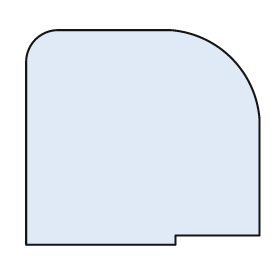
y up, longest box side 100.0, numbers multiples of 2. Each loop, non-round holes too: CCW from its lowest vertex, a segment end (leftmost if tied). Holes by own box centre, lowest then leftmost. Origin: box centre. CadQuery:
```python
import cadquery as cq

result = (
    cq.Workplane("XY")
    .moveTo(-50.0, -46.0)
    .lineTo(14.0, -46.0)
    .lineTo(14.0, -42.0)
    .lineTo(50.0, -42.0)
    .lineTo(50.0, 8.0)
    .threePointArc((38.0, 34.0), (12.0, 46.0))
    .lineTo(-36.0, 46.0)
    .threePointArc((-46.0, 42.0), (-50.0, 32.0))
    .close()
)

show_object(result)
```